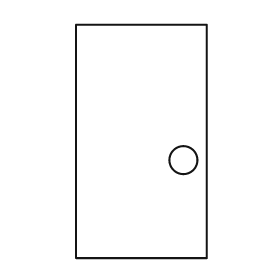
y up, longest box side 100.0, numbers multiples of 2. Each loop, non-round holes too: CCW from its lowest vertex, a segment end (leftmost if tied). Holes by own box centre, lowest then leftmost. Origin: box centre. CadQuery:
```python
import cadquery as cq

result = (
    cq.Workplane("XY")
    .moveTo(-28.0, -50.0)
    .lineTo(28.0, -50.0)
    .lineTo(28.0, 50.0)
    .lineTo(-28.0, 50.0)
    .close()
    .moveTo(18.0, -8.0)
    .circle(6.0)
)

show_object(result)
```